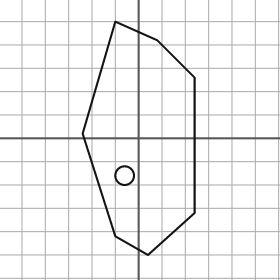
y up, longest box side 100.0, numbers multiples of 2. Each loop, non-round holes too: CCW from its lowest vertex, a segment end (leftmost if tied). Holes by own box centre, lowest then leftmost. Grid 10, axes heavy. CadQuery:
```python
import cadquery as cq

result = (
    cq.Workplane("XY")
    .moveTo(4.0, -50.0)
    .lineTo(24.0, -32.0)
    .lineTo(24.0, 26.0)
    .lineTo(8.0, 42.0)
    .lineTo(-10.0, 50.0)
    .lineTo(-24.0, 2.0)
    .lineTo(-10.0, -42.0)
    .close()
    .moveTo(-6.0, -16.0)
    .circle(4.0)
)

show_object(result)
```